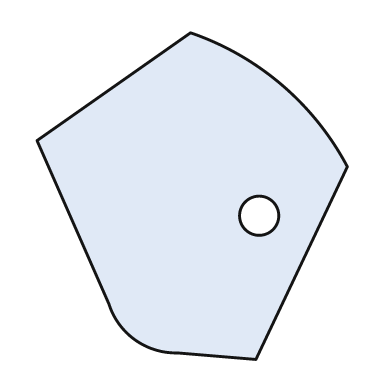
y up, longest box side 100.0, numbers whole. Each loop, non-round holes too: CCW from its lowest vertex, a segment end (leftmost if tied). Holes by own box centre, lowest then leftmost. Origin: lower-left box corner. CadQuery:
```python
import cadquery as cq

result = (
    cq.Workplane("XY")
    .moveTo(67.0, 0.0)
    .lineTo(95.0, 59.0)
    .threePointArc((75.0, 84.0), (47.0, 100.0))
    .lineTo(0.0, 67.0)
    .lineTo(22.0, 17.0)
    .threePointArc((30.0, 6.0), (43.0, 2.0))
    .close()
    .moveTo(68.0, 44.0)
    .circle(6.0)
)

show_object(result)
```